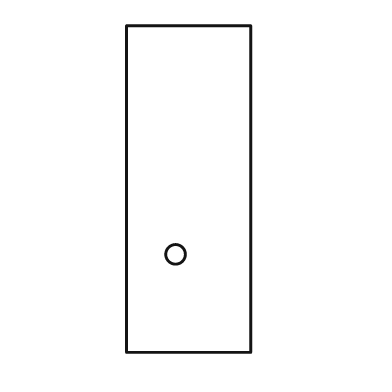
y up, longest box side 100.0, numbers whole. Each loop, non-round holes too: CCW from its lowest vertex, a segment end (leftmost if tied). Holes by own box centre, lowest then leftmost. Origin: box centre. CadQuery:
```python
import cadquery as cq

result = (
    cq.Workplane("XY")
    .moveTo(-19.0, -50.0)
    .lineTo(19.0, -50.0)
    .lineTo(19.0, 50.0)
    .lineTo(-19.0, 50.0)
    .close()
    .moveTo(-4.0, -20.0)
    .circle(3.0)
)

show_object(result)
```